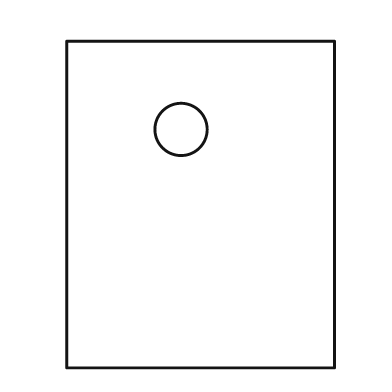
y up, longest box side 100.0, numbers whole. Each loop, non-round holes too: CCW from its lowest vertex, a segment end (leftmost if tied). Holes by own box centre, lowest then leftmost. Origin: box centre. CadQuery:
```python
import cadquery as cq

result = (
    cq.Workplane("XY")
    .moveTo(-41.0, -50.0)
    .lineTo(41.0, -50.0)
    .lineTo(41.0, 50.0)
    .lineTo(-41.0, 50.0)
    .close()
    .moveTo(-6.0, 23.0)
    .circle(8.0)
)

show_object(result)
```